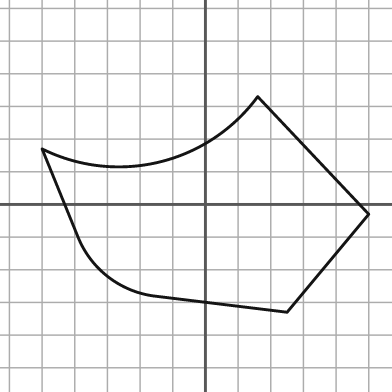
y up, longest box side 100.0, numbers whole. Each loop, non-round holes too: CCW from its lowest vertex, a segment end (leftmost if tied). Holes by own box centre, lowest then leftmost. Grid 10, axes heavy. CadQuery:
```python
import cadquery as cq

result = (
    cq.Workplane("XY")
    .moveTo(25.0, -33.0)
    .lineTo(50.0, -3.0)
    .lineTo(16.0, 33.0)
    .threePointArc((-14.0, 13.0), (-50.0, 17.0))
    .lineTo(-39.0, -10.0)
    .threePointArc((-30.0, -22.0), (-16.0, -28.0))
    .close()
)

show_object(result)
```